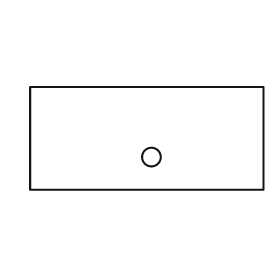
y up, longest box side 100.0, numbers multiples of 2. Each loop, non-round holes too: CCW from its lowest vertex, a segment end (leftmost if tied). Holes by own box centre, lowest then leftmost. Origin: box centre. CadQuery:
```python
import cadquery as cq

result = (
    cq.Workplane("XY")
    .moveTo(-50.0, -22.0)
    .lineTo(50.0, -22.0)
    .lineTo(50.0, 22.0)
    .lineTo(-50.0, 22.0)
    .close()
    .moveTo(2.0, -8.0)
    .circle(4.0)
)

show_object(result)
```